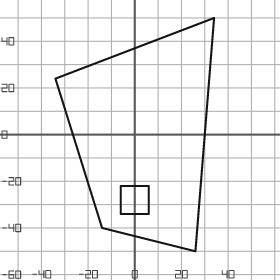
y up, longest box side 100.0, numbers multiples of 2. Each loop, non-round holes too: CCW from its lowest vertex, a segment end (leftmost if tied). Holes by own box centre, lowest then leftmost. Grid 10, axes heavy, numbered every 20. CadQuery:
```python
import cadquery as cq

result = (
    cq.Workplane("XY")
    .moveTo(26.0, -50.0)
    .lineTo(34.0, 50.0)
    .lineTo(-34.0, 24.0)
    .lineTo(-14.0, -40.0)
    .close()
    .moveTo(-6.0, -34.0)
    .lineTo(6.0, -34.0)
    .lineTo(6.0, -22.0)
    .lineTo(-6.0, -22.0)
    .close()
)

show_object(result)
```